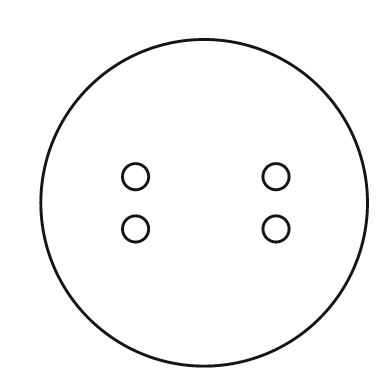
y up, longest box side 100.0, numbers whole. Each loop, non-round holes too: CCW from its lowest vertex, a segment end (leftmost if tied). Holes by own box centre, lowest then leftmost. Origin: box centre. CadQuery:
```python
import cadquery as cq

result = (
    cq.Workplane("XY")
    .moveTo(0.0, 0.0)
    .circle(50.0)
    .moveTo(-21.0, -8.0)
    .circle(4.0)
    .moveTo(22.0, -8.0)
    .circle(4.0)
    .moveTo(-21.0, 8.0)
    .circle(4.0)
    .moveTo(22.0, 8.0)
    .circle(4.0)
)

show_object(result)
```